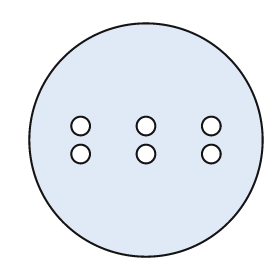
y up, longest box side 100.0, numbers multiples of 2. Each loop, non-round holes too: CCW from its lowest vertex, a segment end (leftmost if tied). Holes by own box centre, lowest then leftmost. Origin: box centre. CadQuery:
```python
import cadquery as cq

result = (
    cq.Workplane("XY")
    .moveTo(0.0, 0.0)
    .circle(50.0)
    .moveTo(-28.0, -6.0)
    .circle(4.0)
    .moveTo(0.0, -6.0)
    .circle(4.0)
    .moveTo(28.0, -6.0)
    .circle(4.0)
    .moveTo(-28.0, 6.0)
    .circle(4.0)
    .moveTo(0.0, 6.0)
    .circle(4.0)
    .moveTo(28.0, 6.0)
    .circle(4.0)
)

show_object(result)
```